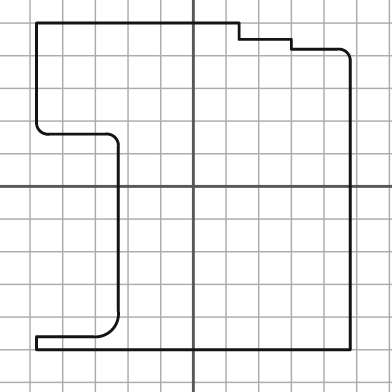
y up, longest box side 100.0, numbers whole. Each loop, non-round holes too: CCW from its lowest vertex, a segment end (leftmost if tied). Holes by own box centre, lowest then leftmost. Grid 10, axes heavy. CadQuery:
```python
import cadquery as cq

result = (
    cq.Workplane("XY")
    .moveTo(-48.0, -50.0)
    .lineTo(48.0, -50.0)
    .lineTo(48.0, 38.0)
    .threePointArc((47.0, 41.0), (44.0, 42.0))
    .lineTo(30.0, 42.0)
    .lineTo(30.0, 45.0)
    .lineTo(14.0, 45.0)
    .lineTo(14.0, 50.0)
    .lineTo(-48.0, 50.0)
    .lineTo(-48.0, 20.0)
    .threePointArc((-47.0, 17.0), (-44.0, 16.0))
    .lineTo(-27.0, 16.0)
    .threePointArc((-24.0, 15.0), (-23.0, 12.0))
    .lineTo(-23.0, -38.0)
    .threePointArc((-25.0, -44.0), (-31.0, -46.0))
    .lineTo(-48.0, -46.0)
    .close()
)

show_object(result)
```